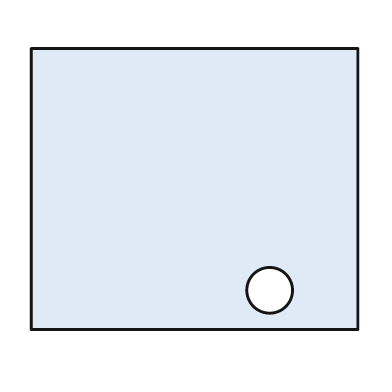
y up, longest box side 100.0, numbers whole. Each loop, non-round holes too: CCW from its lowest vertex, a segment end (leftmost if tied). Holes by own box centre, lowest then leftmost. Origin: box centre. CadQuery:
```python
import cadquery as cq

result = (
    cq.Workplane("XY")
    .moveTo(-50.0, -43.0)
    .lineTo(50.0, -43.0)
    .lineTo(50.0, 43.0)
    .lineTo(-50.0, 43.0)
    .close()
    .moveTo(23.0, -31.0)
    .circle(7.0)
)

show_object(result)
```